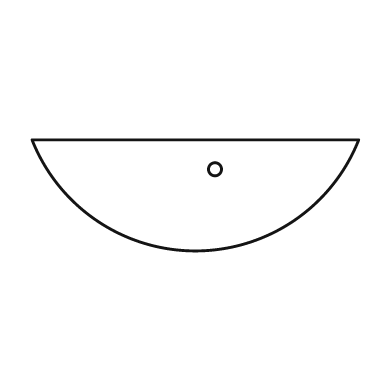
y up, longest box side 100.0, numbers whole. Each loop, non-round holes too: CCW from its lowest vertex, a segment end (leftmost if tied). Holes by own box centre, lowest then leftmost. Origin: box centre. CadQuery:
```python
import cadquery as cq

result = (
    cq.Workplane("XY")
    .moveTo(-50.0, 17.0)
    .threePointArc((0.0, -17.0), (50.0, 17.0))
    .close()
    .moveTo(6.0, 8.0)
    .circle(2.0)
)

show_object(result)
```